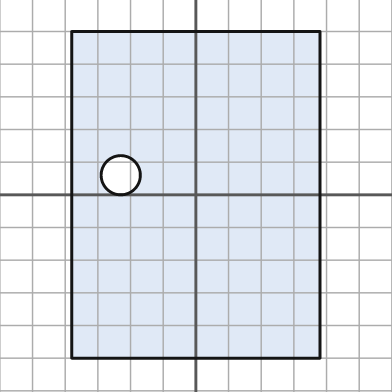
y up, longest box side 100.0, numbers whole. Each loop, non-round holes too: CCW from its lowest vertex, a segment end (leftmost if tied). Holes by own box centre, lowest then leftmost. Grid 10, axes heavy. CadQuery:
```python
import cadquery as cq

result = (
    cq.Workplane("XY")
    .moveTo(-38.0, -50.0)
    .lineTo(38.0, -50.0)
    .lineTo(38.0, 50.0)
    .lineTo(-38.0, 50.0)
    .close()
    .moveTo(-23.0, 6.0)
    .circle(6.0)
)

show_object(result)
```